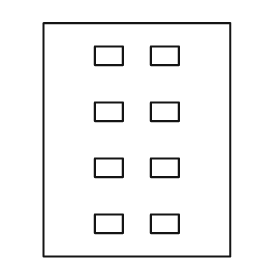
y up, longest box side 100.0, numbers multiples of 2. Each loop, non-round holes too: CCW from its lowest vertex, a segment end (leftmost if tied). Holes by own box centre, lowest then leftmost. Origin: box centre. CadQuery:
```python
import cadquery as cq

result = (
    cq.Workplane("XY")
    .moveTo(-40.0, -50.0)
    .lineTo(40.0, -50.0)
    .lineTo(40.0, 50.0)
    .lineTo(-40.0, 50.0)
    .close()
    .moveTo(-18.0, -40.0)
    .lineTo(-6.0, -40.0)
    .lineTo(-6.0, -32.0)
    .lineTo(-18.0, -32.0)
    .close()
    .moveTo(6.0, -40.0)
    .lineTo(18.0, -40.0)
    .lineTo(18.0, -32.0)
    .lineTo(6.0, -32.0)
    .close()
    .moveTo(-18.0, -16.0)
    .lineTo(-6.0, -16.0)
    .lineTo(-6.0, -8.0)
    .lineTo(-18.0, -8.0)
    .close()
    .moveTo(6.0, -16.0)
    .lineTo(18.0, -16.0)
    .lineTo(18.0, -8.0)
    .lineTo(6.0, -8.0)
    .close()
    .moveTo(-18.0, 8.0)
    .lineTo(-6.0, 8.0)
    .lineTo(-6.0, 16.0)
    .lineTo(-18.0, 16.0)
    .close()
    .moveTo(6.0, 8.0)
    .lineTo(18.0, 8.0)
    .lineTo(18.0, 16.0)
    .lineTo(6.0, 16.0)
    .close()
    .moveTo(-18.0, 32.0)
    .lineTo(-6.0, 32.0)
    .lineTo(-6.0, 40.0)
    .lineTo(-18.0, 40.0)
    .close()
    .moveTo(6.0, 32.0)
    .lineTo(18.0, 32.0)
    .lineTo(18.0, 40.0)
    .lineTo(6.0, 40.0)
    .close()
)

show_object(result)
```